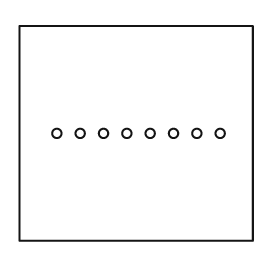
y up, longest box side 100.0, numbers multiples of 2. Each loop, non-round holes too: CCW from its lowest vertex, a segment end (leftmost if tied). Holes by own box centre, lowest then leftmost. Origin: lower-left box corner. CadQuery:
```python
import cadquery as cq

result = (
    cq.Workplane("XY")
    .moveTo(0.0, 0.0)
    .lineTo(100.0, 0.0)
    .lineTo(100.0, 92.0)
    .lineTo(0.0, 92.0)
    .close()
    .moveTo(16.0, 46.0)
    .circle(2.0)
    .moveTo(26.0, 46.0)
    .circle(2.0)
    .moveTo(36.0, 46.0)
    .circle(2.0)
    .moveTo(46.0, 46.0)
    .circle(2.0)
    .moveTo(56.0, 46.0)
    .circle(2.0)
    .moveTo(66.0, 46.0)
    .circle(2.0)
    .moveTo(76.0, 46.0)
    .circle(2.0)
    .moveTo(86.0, 46.0)
    .circle(2.0)
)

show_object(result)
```